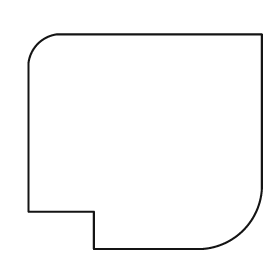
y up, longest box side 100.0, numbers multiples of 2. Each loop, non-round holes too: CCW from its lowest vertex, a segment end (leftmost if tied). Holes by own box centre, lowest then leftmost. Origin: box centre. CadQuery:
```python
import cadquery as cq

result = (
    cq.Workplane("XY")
    .moveTo(-22.0, -46.0)
    .lineTo(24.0, -46.0)
    .threePointArc((42.0, -38.0), (50.0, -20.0))
    .lineTo(50.0, 46.0)
    .lineTo(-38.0, 46.0)
    .threePointArc((-46.0, 42.0), (-50.0, 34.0))
    .lineTo(-50.0, -30.0)
    .lineTo(-22.0, -30.0)
    .close()
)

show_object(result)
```